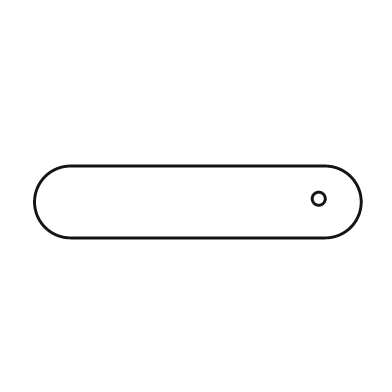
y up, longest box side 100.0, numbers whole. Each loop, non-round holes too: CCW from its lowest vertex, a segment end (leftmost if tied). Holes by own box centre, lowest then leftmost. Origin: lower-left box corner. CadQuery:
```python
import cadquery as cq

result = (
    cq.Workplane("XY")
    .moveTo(11.0, 0.0)
    .lineTo(89.0, 0.0)
    .threePointArc((100.0, 11.0), (89.0, 22.0))
    .lineTo(11.0, 22.0)
    .threePointArc((0.0, 11.0), (11.0, 0.0))
    .close()
    .moveTo(87.0, 12.0)
    .circle(2.0)
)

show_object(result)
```